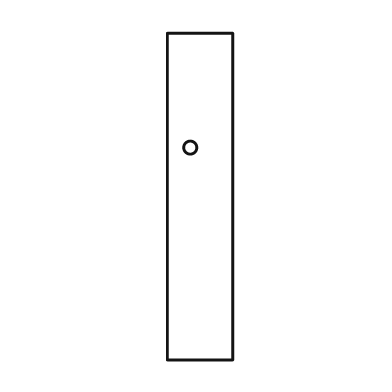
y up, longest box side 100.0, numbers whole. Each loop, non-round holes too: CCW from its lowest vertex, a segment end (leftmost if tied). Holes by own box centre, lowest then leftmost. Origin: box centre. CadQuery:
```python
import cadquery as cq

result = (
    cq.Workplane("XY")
    .moveTo(-10.0, -50.0)
    .lineTo(10.0, -50.0)
    .lineTo(10.0, 50.0)
    .lineTo(-10.0, 50.0)
    .close()
    .moveTo(-3.0, 15.0)
    .circle(2.0)
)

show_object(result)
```